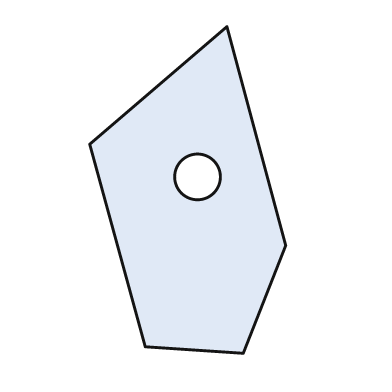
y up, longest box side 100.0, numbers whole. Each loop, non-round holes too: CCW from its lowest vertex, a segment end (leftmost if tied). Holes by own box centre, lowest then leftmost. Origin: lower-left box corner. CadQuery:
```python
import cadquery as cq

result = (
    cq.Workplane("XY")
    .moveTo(47.0, 0.0)
    .lineTo(60.0, 33.0)
    .lineTo(42.0, 100.0)
    .lineTo(0.0, 64.0)
    .lineTo(17.0, 2.0)
    .close()
    .moveTo(33.0, 54.0)
    .circle(7.0)
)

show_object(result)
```